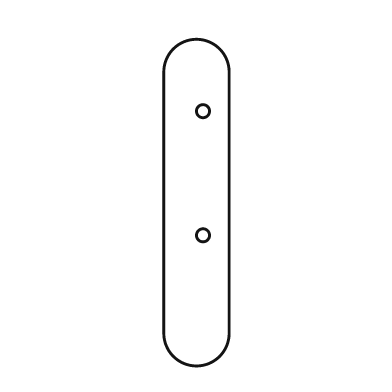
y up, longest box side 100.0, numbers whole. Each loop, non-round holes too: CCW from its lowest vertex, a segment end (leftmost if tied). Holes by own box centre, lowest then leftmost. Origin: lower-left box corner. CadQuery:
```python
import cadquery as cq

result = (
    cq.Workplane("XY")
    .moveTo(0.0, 10.0)
    .threePointArc((10.0, 0.0), (20.0, 10.0))
    .lineTo(20.0, 90.0)
    .threePointArc((10.0, 100.0), (0.0, 90.0))
    .close()
    .moveTo(12.0, 40.0)
    .circle(2.0)
    .moveTo(12.0, 78.0)
    .circle(2.0)
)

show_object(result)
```